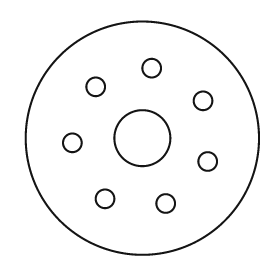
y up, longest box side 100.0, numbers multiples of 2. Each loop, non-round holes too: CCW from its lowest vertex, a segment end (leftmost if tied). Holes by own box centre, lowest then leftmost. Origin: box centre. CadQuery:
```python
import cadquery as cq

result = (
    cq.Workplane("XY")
    .moveTo(0.0, 0.0)
    .circle(50.0)
    .moveTo(10.0, -28.0)
    .circle(4.0)
    .moveTo(-16.0, -26.0)
    .circle(4.0)
    .moveTo(28.0, -10.0)
    .circle(4.0)
    .moveTo(-30.0, -2.0)
    .circle(4.0)
    .moveTo(0.0, 0.0)
    .circle(12.0)
    .moveTo(26.0, 16.0)
    .circle(4.0)
    .moveTo(-20.0, 22.0)
    .circle(4.0)
    .moveTo(4.0, 30.0)
    .circle(4.0)
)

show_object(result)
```